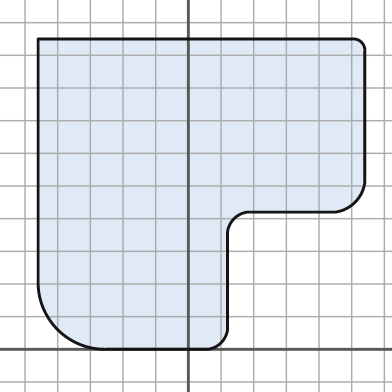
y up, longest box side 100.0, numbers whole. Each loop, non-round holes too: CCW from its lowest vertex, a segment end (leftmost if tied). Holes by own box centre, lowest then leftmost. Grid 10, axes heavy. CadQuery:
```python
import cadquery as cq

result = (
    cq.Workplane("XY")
    .moveTo(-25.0, 0.0)
    .lineTo(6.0, 0.0)
    .threePointArc((10.0, 2.0), (12.0, 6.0))
    .lineTo(12.0, 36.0)
    .threePointArc((14.0, 40.0), (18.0, 42.0))
    .lineTo(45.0, 42.0)
    .threePointArc((51.0, 45.0), (54.0, 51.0))
    .lineTo(54.0, 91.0)
    .threePointArc((53.0, 94.0), (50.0, 95.0))
    .lineTo(-46.0, 95.0)
    .lineTo(-46.0, 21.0)
    .threePointArc((-40.0, 6.0), (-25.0, 0.0))
    .close()
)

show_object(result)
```